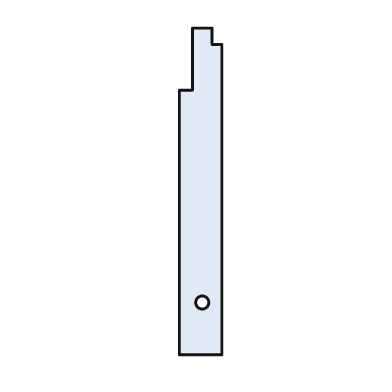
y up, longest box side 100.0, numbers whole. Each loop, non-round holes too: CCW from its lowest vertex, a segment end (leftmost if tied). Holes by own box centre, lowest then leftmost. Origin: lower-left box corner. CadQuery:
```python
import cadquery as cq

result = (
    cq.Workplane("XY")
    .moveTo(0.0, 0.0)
    .lineTo(13.0, 0.0)
    .lineTo(13.0, 95.0)
    .lineTo(10.0, 95.0)
    .lineTo(10.0, 100.0)
    .lineTo(4.0, 100.0)
    .lineTo(4.0, 81.0)
    .lineTo(0.0, 81.0)
    .close()
    .moveTo(7.0, 16.0)
    .circle(2.0)
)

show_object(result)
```